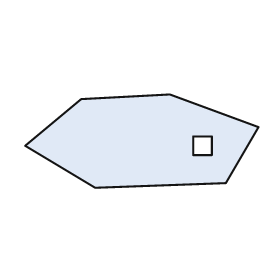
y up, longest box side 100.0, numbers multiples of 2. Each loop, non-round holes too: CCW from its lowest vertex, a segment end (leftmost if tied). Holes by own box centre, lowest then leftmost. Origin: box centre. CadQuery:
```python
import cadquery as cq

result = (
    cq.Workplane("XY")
    .moveTo(-20.0, -20.0)
    .lineTo(36.0, -18.0)
    .lineTo(50.0, 6.0)
    .lineTo(12.0, 20.0)
    .lineTo(-26.0, 18.0)
    .lineTo(-50.0, -2.0)
    .close()
    .moveTo(22.0, -6.0)
    .lineTo(30.0, -6.0)
    .lineTo(30.0, 2.0)
    .lineTo(22.0, 2.0)
    .close()
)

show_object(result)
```